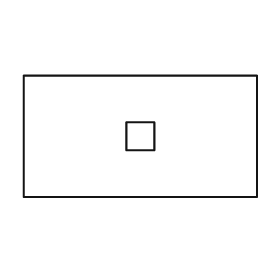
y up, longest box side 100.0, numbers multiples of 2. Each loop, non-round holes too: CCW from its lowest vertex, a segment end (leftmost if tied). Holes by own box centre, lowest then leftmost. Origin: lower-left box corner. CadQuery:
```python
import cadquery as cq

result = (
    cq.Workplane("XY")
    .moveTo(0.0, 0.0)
    .lineTo(100.0, 0.0)
    .lineTo(100.0, 52.0)
    .lineTo(0.0, 52.0)
    .close()
    .moveTo(44.0, 20.0)
    .lineTo(56.0, 20.0)
    .lineTo(56.0, 32.0)
    .lineTo(44.0, 32.0)
    .close()
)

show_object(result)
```